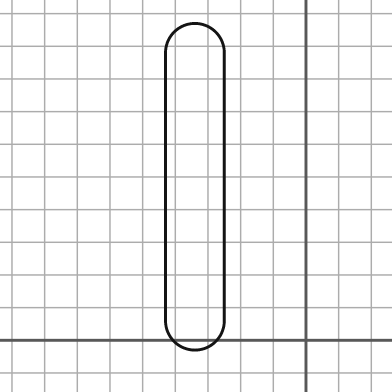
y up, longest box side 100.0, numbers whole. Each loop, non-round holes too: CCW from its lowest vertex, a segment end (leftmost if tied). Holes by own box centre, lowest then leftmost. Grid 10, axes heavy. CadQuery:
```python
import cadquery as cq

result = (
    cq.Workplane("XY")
    .moveTo(-43.0, 6.0)
    .threePointArc((-34.0, -3.0), (-25.0, 6.0))
    .lineTo(-25.0, 88.0)
    .threePointArc((-34.0, 97.0), (-43.0, 88.0))
    .close()
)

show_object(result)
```